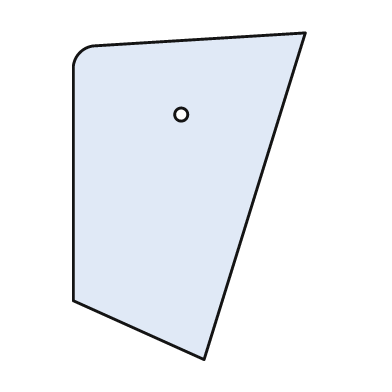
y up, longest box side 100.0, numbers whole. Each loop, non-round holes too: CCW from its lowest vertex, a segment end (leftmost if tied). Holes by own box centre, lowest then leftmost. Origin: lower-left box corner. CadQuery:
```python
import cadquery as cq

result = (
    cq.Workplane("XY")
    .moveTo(40.0, 0.0)
    .lineTo(71.0, 100.0)
    .lineTo(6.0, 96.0)
    .threePointArc((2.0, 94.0), (0.0, 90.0))
    .lineTo(0.0, 18.0)
    .close()
    .moveTo(33.0, 75.0)
    .circle(2.0)
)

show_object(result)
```